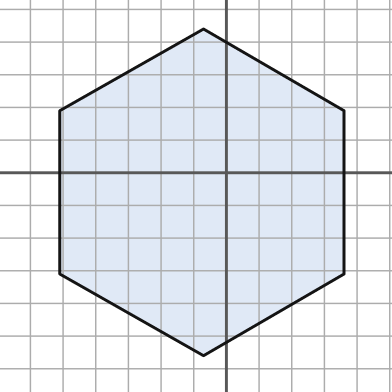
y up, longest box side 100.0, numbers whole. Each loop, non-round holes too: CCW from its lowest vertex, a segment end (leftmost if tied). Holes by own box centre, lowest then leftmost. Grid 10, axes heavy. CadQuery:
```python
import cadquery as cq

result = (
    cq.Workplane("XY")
    .moveTo(-7.0, -56.0)
    .lineTo(36.0, -31.0)
    .lineTo(36.0, 19.0)
    .lineTo(-7.0, 44.0)
    .lineTo(-51.0, 19.0)
    .lineTo(-51.0, -31.0)
    .close()
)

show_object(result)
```